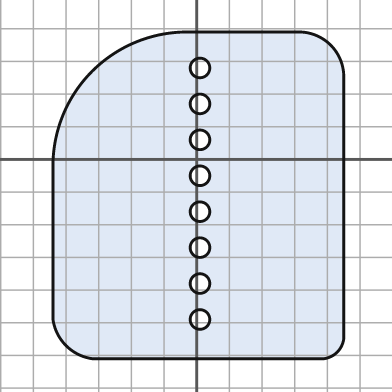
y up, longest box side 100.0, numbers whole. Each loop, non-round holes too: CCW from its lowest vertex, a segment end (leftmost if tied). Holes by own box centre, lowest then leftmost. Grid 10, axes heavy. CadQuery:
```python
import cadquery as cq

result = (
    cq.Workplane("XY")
    .moveTo(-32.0, -61.0)
    .lineTo(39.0, -61.0)
    .threePointArc((43.0, -59.0), (45.0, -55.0))
    .lineTo(45.0, 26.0)
    .threePointArc((41.0, 35.0), (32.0, 39.0))
    .lineTo(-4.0, 39.0)
    .threePointArc((-32.0, 27.0), (-44.0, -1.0))
    .lineTo(-44.0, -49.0)
    .threePointArc((-40.0, -57.0), (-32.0, -61.0))
    .close()
    .moveTo(1.0, -49.0)
    .circle(3.0)
    .moveTo(1.0, -38.0)
    .circle(3.0)
    .moveTo(1.0, -27.0)
    .circle(3.0)
    .moveTo(1.0, -16.0)
    .circle(3.0)
    .moveTo(1.0, -5.0)
    .circle(3.0)
    .moveTo(1.0, 6.0)
    .circle(3.0)
    .moveTo(1.0, 17.0)
    .circle(3.0)
    .moveTo(1.0, 28.0)
    .circle(3.0)
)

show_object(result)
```